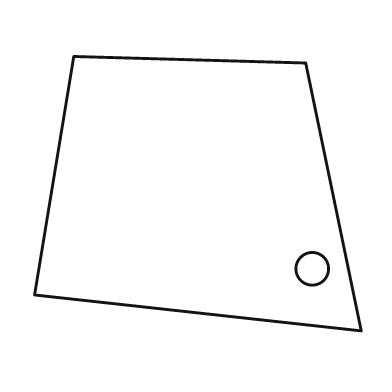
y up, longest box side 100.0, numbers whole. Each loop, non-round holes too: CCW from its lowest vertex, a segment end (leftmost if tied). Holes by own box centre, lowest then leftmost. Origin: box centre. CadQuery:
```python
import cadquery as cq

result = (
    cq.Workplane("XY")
    .moveTo(50.0, -42.0)
    .lineTo(33.0, 40.0)
    .lineTo(-38.0, 42.0)
    .lineTo(-50.0, -31.0)
    .close()
    .moveTo(35.0, -23.0)
    .circle(5.0)
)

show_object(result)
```